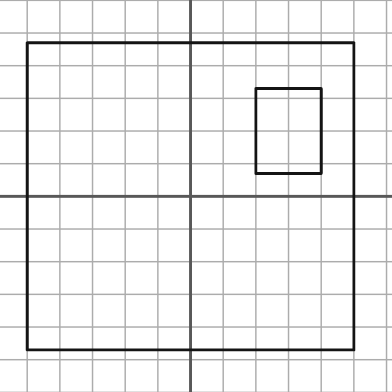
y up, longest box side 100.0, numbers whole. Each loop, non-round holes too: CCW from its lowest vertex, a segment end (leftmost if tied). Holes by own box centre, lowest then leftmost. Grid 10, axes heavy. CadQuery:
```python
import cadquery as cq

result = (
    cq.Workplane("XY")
    .moveTo(-50.0, -47.0)
    .lineTo(50.0, -47.0)
    .lineTo(50.0, 47.0)
    .lineTo(-50.0, 47.0)
    .close()
    .moveTo(20.0, 7.0)
    .lineTo(40.0, 7.0)
    .lineTo(40.0, 33.0)
    .lineTo(20.0, 33.0)
    .close()
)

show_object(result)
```